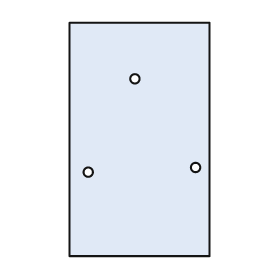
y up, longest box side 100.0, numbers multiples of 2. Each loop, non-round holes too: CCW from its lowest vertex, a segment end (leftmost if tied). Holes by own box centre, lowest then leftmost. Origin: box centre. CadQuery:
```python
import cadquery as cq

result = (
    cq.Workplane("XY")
    .moveTo(-30.0, -50.0)
    .lineTo(30.0, -50.0)
    .lineTo(30.0, 50.0)
    .lineTo(-30.0, 50.0)
    .close()
    .moveTo(-22.0, -14.0)
    .circle(2.0)
    .moveTo(24.0, -12.0)
    .circle(2.0)
    .moveTo(-2.0, 26.0)
    .circle(2.0)
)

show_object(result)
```